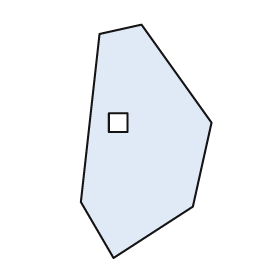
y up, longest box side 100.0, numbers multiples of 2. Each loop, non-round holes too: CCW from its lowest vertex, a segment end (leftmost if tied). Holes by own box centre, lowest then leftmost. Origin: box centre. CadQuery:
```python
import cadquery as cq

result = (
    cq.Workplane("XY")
    .moveTo(-14.0, -50.0)
    .lineTo(20.0, -28.0)
    .lineTo(28.0, 8.0)
    .lineTo(-2.0, 50.0)
    .lineTo(-20.0, 46.0)
    .lineTo(-28.0, -26.0)
    .close()
    .moveTo(-16.0, 4.0)
    .lineTo(-8.0, 4.0)
    .lineTo(-8.0, 12.0)
    .lineTo(-16.0, 12.0)
    .close()
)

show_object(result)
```